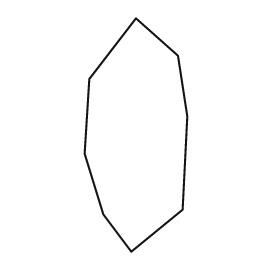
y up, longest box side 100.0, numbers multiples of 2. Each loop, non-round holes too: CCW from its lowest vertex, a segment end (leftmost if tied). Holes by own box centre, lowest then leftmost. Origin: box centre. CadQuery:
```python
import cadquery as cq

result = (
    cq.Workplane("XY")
    .moveTo(-2.0, -50.0)
    .lineTo(20.0, -32.0)
    .lineTo(22.0, 8.0)
    .lineTo(18.0, 34.0)
    .lineTo(0.0, 50.0)
    .lineTo(-20.0, 24.0)
    .lineTo(-22.0, -8.0)
    .lineTo(-14.0, -34.0)
    .close()
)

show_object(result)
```